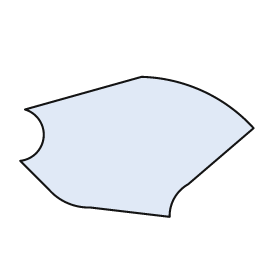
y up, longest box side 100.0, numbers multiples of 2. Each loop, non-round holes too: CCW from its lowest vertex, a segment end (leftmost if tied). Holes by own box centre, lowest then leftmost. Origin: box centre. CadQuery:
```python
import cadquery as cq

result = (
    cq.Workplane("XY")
    .moveTo(14.0, -30.0)
    .threePointArc((16.0, -22.0), (22.0, -16.0))
    .lineTo(50.0, 8.0)
    .threePointArc((28.0, 24.0), (2.0, 30.0))
    .lineTo(-48.0, 16.0)
    .threePointArc((-40.0, 4.0), (-50.0, -6.0))
    .lineTo(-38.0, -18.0)
    .threePointArc((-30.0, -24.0), (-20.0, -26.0))
    .close()
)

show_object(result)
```